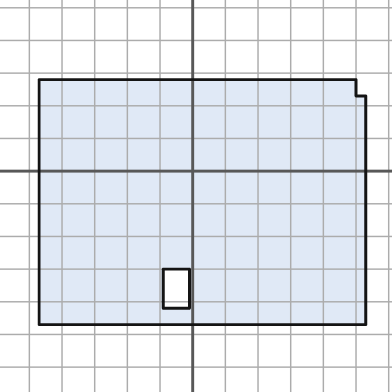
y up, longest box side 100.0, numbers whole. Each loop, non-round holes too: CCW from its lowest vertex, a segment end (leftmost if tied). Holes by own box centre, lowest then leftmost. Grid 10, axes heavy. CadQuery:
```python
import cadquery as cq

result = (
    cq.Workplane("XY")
    .moveTo(-47.0, -47.0)
    .lineTo(53.0, -47.0)
    .lineTo(53.0, 23.0)
    .lineTo(50.0, 23.0)
    .lineTo(50.0, 28.0)
    .lineTo(-47.0, 28.0)
    .close()
    .moveTo(-9.0, -42.0)
    .lineTo(-1.0, -42.0)
    .lineTo(-1.0, -30.0)
    .lineTo(-9.0, -30.0)
    .close()
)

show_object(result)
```